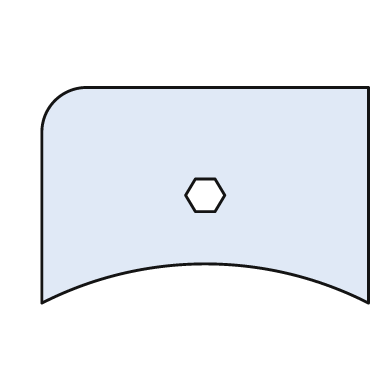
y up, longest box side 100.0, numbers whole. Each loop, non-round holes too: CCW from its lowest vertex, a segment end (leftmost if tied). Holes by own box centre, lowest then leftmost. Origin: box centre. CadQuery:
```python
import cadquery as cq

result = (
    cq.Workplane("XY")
    .moveTo(-50.0, -33.0)
    .threePointArc((0.0, -21.0), (50.0, -33.0))
    .lineTo(50.0, 33.0)
    .lineTo(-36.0, 33.0)
    .threePointArc((-46.0, 29.0), (-50.0, 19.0))
    .close()
    .moveTo(-3.0, -5.0)
    .lineTo(3.0, -5.0)
    .lineTo(6.0, 0.0)
    .lineTo(3.0, 5.0)
    .lineTo(-3.0, 5.0)
    .lineTo(-6.0, 0.0)
    .close()
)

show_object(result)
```